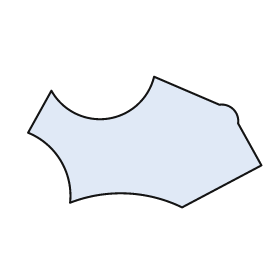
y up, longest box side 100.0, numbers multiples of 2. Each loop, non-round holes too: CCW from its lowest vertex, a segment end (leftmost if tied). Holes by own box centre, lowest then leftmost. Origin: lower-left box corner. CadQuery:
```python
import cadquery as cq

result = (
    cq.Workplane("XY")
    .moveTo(66.0, 0.0)
    .lineTo(100.0, 18.0)
    .lineTo(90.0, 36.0)
    .threePointArc((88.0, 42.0), (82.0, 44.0))
    .lineTo(54.0, 56.0)
    .threePointArc((34.0, 38.0), (10.0, 50.0))
    .lineTo(0.0, 32.0)
    .threePointArc((14.0, 20.0), (18.0, 2.0))
    .threePointArc((42.0, 6.0), (66.0, 0.0))
    .close()
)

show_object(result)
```